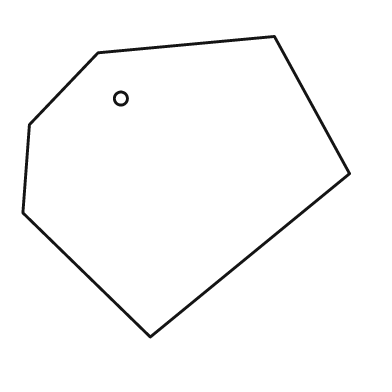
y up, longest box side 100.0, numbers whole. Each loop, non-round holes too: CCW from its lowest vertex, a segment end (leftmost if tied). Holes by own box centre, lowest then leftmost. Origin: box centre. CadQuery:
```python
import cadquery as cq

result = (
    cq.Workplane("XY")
    .moveTo(-11.0, -46.0)
    .lineTo(50.0, 4.0)
    .lineTo(27.0, 46.0)
    .lineTo(-27.0, 41.0)
    .lineTo(-48.0, 19.0)
    .lineTo(-50.0, -8.0)
    .close()
    .moveTo(-20.0, 27.0)
    .circle(2.0)
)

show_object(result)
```